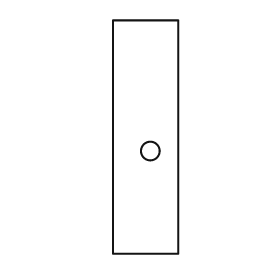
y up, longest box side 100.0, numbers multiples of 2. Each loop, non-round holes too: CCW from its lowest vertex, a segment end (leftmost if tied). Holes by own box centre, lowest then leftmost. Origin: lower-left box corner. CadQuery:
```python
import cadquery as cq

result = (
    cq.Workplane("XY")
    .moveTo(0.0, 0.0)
    .lineTo(28.0, 0.0)
    .lineTo(28.0, 100.0)
    .lineTo(0.0, 100.0)
    .close()
    .moveTo(16.0, 44.0)
    .circle(4.0)
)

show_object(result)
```